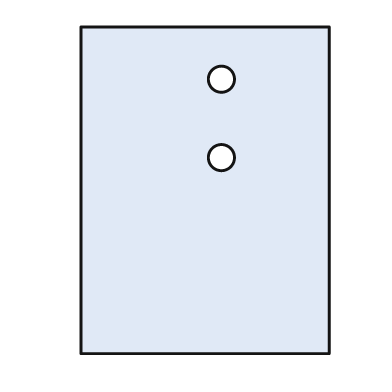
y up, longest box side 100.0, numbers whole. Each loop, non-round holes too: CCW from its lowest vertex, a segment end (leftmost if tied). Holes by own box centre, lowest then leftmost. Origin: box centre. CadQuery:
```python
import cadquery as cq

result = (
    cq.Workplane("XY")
    .moveTo(-38.0, -50.0)
    .lineTo(38.0, -50.0)
    .lineTo(38.0, 50.0)
    .lineTo(-38.0, 50.0)
    .close()
    .moveTo(5.0, 10.0)
    .circle(4.0)
    .moveTo(5.0, 34.0)
    .circle(4.0)
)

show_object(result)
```